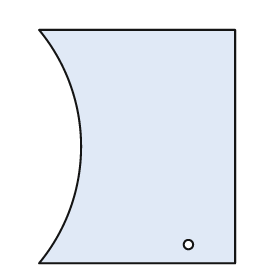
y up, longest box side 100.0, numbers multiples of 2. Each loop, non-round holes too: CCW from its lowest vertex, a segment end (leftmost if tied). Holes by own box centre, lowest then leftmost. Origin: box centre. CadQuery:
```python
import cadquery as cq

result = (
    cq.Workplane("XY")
    .moveTo(-42.0, -50.0)
    .lineTo(42.0, -50.0)
    .lineTo(42.0, 50.0)
    .lineTo(-42.0, 50.0)
    .threePointArc((-24.0, 0.0), (-42.0, -50.0))
    .close()
    .moveTo(22.0, -42.0)
    .circle(2.0)
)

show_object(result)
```